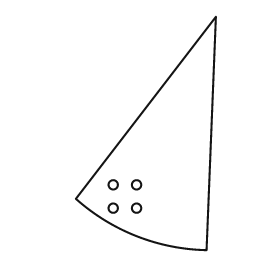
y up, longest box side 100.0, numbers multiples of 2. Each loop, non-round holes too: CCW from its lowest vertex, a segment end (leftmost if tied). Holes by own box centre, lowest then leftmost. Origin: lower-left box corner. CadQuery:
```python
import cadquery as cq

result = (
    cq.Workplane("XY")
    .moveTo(56.0, 0.0)
    .lineTo(60.0, 100.0)
    .lineTo(0.0, 22.0)
    .threePointArc((26.0, 6.0), (56.0, 0.0))
    .close()
    .moveTo(16.0, 18.0)
    .circle(2.0)
    .moveTo(26.0, 18.0)
    .circle(2.0)
    .moveTo(16.0, 28.0)
    .circle(2.0)
    .moveTo(26.0, 28.0)
    .circle(2.0)
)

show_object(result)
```